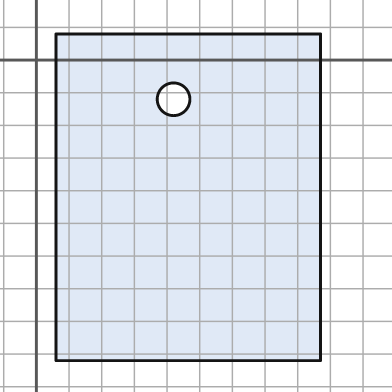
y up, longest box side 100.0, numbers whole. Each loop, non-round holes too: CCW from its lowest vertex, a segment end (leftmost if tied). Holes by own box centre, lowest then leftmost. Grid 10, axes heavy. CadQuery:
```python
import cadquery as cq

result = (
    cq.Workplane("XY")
    .moveTo(6.0, -92.0)
    .lineTo(87.0, -92.0)
    .lineTo(87.0, 8.0)
    .lineTo(6.0, 8.0)
    .close()
    .moveTo(42.0, -12.0)
    .circle(5.0)
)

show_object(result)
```